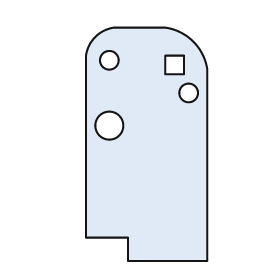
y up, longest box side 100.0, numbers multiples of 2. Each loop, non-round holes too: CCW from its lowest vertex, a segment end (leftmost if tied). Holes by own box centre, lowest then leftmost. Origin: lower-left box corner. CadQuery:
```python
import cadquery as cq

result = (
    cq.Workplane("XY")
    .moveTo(18.0, 0.0)
    .lineTo(52.0, 0.0)
    .lineTo(52.0, 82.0)
    .threePointArc((46.0, 94.0), (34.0, 100.0))
    .lineTo(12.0, 100.0)
    .threePointArc((4.0, 96.0), (0.0, 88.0))
    .lineTo(0.0, 10.0)
    .lineTo(18.0, 10.0)
    .close()
    .moveTo(10.0, 58.0)
    .circle(6.0)
    .moveTo(44.0, 72.0)
    .circle(4.0)
    .moveTo(34.0, 80.0)
    .lineTo(42.0, 80.0)
    .lineTo(42.0, 88.0)
    .lineTo(34.0, 88.0)
    .close()
    .moveTo(10.0, 86.0)
    .circle(4.0)
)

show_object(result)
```